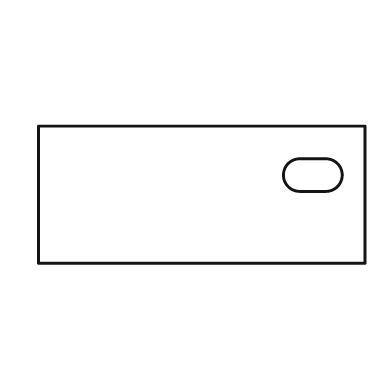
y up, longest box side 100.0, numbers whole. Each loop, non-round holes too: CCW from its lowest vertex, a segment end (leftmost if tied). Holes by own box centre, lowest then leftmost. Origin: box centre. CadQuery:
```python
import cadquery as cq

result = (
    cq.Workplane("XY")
    .moveTo(-50.0, -21.0)
    .lineTo(50.0, -21.0)
    .lineTo(50.0, 21.0)
    .lineTo(-50.0, 21.0)
    .close()
    .moveTo(30.0, 1.0)
    .lineTo(38.0, 1.0)
    .threePointArc((43.0, 6.0), (38.0, 11.0))
    .lineTo(30.0, 11.0)
    .threePointArc((25.0, 6.0), (30.0, 1.0))
    .close()
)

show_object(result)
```